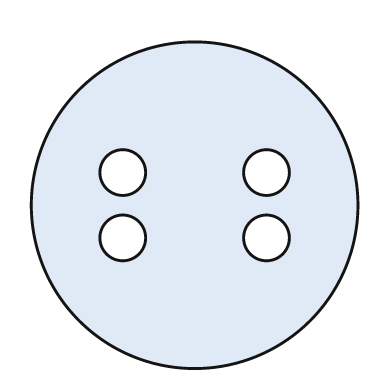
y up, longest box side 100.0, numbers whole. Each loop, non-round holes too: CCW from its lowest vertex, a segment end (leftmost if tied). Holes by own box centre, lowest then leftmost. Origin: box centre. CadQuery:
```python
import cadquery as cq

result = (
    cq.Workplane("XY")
    .moveTo(0.0, 0.0)
    .circle(50.0)
    .moveTo(-22.0, -10.0)
    .circle(7.0)
    .moveTo(22.0, -10.0)
    .circle(7.0)
    .moveTo(-22.0, 10.0)
    .circle(7.0)
    .moveTo(22.0, 10.0)
    .circle(7.0)
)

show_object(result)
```